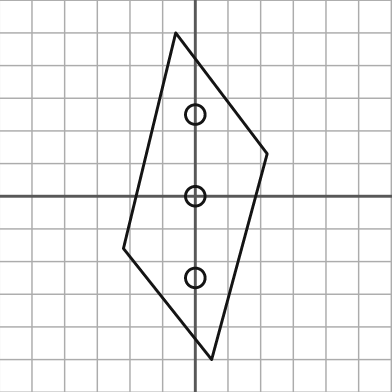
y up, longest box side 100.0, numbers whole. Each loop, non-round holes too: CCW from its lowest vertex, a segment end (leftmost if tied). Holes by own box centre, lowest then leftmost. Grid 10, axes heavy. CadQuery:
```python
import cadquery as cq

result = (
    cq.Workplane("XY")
    .moveTo(5.0, -50.0)
    .lineTo(22.0, 13.0)
    .lineTo(-6.0, 50.0)
    .lineTo(-22.0, -16.0)
    .close()
    .moveTo(0.0, -25.0)
    .circle(3.0)
    .moveTo(0.0, 0.0)
    .circle(3.0)
    .moveTo(0.0, 25.0)
    .circle(3.0)
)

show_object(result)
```